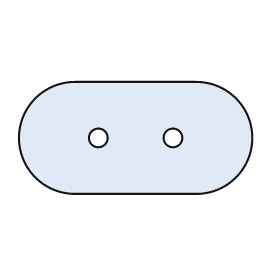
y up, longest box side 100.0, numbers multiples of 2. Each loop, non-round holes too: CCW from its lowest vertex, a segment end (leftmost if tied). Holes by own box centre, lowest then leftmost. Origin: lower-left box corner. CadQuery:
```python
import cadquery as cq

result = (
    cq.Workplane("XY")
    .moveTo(24.0, 0.0)
    .lineTo(76.0, 0.0)
    .threePointArc((100.0, 24.0), (76.0, 48.0))
    .lineTo(24.0, 48.0)
    .threePointArc((0.0, 24.0), (24.0, 0.0))
    .close()
    .moveTo(34.0, 24.0)
    .circle(4.0)
    .moveTo(66.0, 24.0)
    .circle(4.0)
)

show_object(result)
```